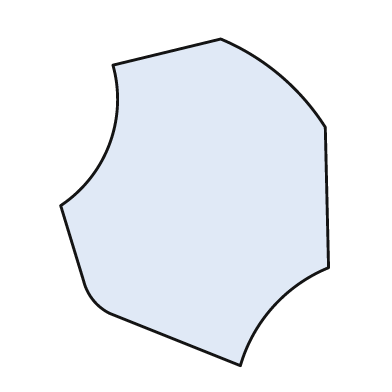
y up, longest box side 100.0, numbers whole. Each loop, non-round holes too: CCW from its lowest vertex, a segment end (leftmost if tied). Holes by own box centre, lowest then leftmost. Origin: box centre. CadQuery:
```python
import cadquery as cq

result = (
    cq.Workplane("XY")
    .moveTo(14.0, -50.0)
    .threePointArc((24.0, -32.0), (41.0, -20.0))
    .lineTo(40.0, 23.0)
    .threePointArc((26.0, 39.0), (8.0, 50.0))
    .lineTo(-25.0, 42.0)
    .threePointArc((-26.0, 18.0), (-41.0, -1.0))
    .lineTo(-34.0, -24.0)
    .threePointArc((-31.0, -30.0), (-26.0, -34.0))
    .close()
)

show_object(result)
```